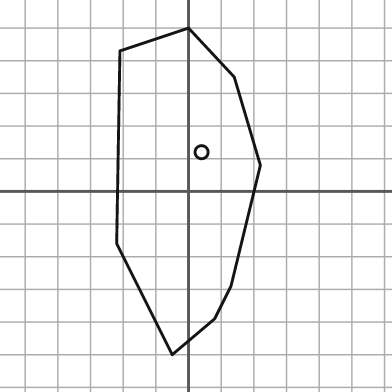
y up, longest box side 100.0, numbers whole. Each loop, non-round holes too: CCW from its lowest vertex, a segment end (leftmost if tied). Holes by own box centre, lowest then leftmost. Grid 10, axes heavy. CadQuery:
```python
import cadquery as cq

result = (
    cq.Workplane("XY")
    .moveTo(-5.0, -50.0)
    .lineTo(8.0, -39.0)
    .lineTo(13.0, -29.0)
    .lineTo(22.0, 8.0)
    .lineTo(14.0, 35.0)
    .lineTo(0.0, 50.0)
    .lineTo(-21.0, 43.0)
    .lineTo(-22.0, -16.0)
    .close()
    .moveTo(4.0, 12.0)
    .circle(2.0)
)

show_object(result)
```